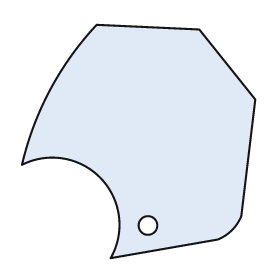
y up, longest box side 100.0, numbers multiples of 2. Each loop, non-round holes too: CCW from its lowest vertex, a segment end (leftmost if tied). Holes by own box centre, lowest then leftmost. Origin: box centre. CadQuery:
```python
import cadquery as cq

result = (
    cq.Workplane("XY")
    .moveTo(-12.0, -50.0)
    .lineTo(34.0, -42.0)
    .threePointArc((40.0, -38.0), (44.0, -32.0))
    .lineTo(50.0, 18.0)
    .lineTo(26.0, 48.0)
    .lineTo(-18.0, 50.0)
    .threePointArc((-38.0, 22.0), (-50.0, -10.0))
    .threePointArc((-16.0, -16.0), (-12.0, -50.0))
    .close()
    .moveTo(4.0, -36.0)
    .circle(4.0)
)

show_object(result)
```